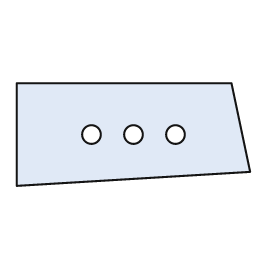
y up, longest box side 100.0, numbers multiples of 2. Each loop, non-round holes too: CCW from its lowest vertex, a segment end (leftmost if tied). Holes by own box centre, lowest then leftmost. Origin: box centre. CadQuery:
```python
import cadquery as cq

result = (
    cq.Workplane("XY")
    .moveTo(-50.0, -22.0)
    .lineTo(50.0, -16.0)
    .lineTo(42.0, 22.0)
    .lineTo(-50.0, 22.0)
    .close()
    .moveTo(-18.0, 0.0)
    .circle(4.0)
    .moveTo(0.0, 0.0)
    .circle(4.0)
    .moveTo(18.0, 0.0)
    .circle(4.0)
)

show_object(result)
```